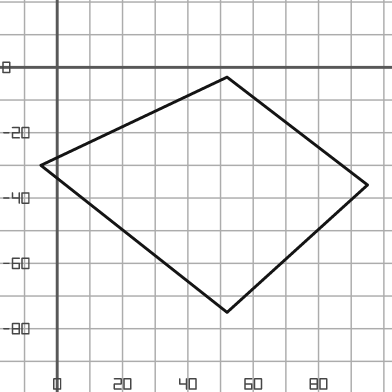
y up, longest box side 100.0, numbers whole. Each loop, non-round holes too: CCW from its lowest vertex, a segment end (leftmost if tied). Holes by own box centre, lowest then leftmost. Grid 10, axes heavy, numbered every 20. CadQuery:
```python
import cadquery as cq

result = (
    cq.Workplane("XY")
    .moveTo(52.0, -75.0)
    .lineTo(95.0, -36.0)
    .lineTo(52.0, -3.0)
    .lineTo(-5.0, -30.0)
    .close()
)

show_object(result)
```